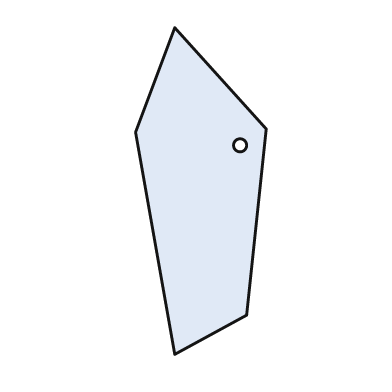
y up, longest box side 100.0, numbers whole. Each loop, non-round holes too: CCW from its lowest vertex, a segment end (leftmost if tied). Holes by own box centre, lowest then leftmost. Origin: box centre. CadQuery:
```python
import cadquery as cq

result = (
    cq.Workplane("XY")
    .moveTo(-8.0, -50.0)
    .lineTo(14.0, -38.0)
    .lineTo(20.0, 19.0)
    .lineTo(-8.0, 50.0)
    .lineTo(-20.0, 18.0)
    .close()
    .moveTo(12.0, 14.0)
    .circle(2.0)
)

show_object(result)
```